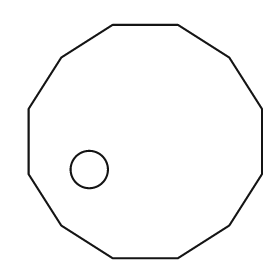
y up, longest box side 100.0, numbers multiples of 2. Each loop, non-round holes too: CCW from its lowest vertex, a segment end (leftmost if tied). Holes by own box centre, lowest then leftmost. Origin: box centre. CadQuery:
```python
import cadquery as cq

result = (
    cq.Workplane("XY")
    .moveTo(-14.0, -50.0)
    .lineTo(14.0, -50.0)
    .lineTo(36.0, -36.0)
    .lineTo(50.0, -14.0)
    .lineTo(50.0, 14.0)
    .lineTo(36.0, 36.0)
    .lineTo(14.0, 50.0)
    .lineTo(-14.0, 50.0)
    .lineTo(-36.0, 36.0)
    .lineTo(-50.0, 14.0)
    .lineTo(-50.0, -14.0)
    .lineTo(-36.0, -36.0)
    .close()
    .moveTo(-24.0, -12.0)
    .circle(8.0)
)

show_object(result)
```